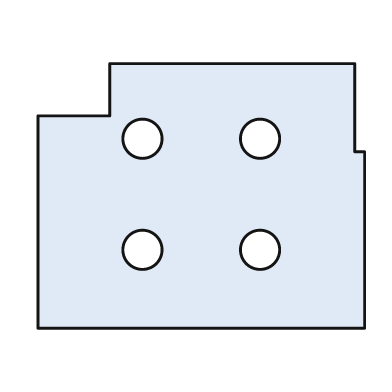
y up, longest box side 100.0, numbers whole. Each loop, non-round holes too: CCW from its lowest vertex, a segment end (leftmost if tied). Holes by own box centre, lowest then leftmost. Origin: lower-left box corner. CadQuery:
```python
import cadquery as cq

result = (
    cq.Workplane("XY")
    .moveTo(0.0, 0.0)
    .lineTo(100.0, 0.0)
    .lineTo(100.0, 54.0)
    .lineTo(97.0, 54.0)
    .lineTo(97.0, 81.0)
    .lineTo(22.0, 81.0)
    .lineTo(22.0, 65.0)
    .lineTo(0.0, 65.0)
    .close()
    .moveTo(32.0, 24.0)
    .circle(6.0)
    .moveTo(68.0, 24.0)
    .circle(6.0)
    .moveTo(32.0, 58.0)
    .circle(6.0)
    .moveTo(68.0, 58.0)
    .circle(6.0)
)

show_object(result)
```